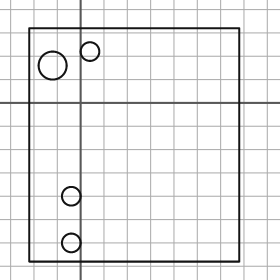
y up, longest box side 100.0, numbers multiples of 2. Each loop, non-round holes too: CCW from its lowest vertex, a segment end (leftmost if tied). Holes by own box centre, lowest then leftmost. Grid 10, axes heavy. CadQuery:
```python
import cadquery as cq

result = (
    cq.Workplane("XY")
    .moveTo(-22.0, -68.0)
    .lineTo(68.0, -68.0)
    .lineTo(68.0, 32.0)
    .lineTo(-22.0, 32.0)
    .close()
    .moveTo(-4.0, -60.0)
    .circle(4.0)
    .moveTo(-4.0, -40.0)
    .circle(4.0)
    .moveTo(-12.0, 16.0)
    .circle(6.0)
    .moveTo(4.0, 22.0)
    .circle(4.0)
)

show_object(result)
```